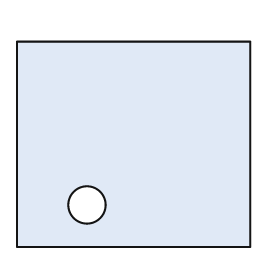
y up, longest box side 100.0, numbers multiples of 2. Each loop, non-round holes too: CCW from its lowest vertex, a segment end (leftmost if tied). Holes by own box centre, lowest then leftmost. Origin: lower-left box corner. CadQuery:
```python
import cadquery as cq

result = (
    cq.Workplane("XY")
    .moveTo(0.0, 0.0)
    .lineTo(100.0, 0.0)
    .lineTo(100.0, 88.0)
    .lineTo(0.0, 88.0)
    .close()
    .moveTo(30.0, 18.0)
    .circle(8.0)
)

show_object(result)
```